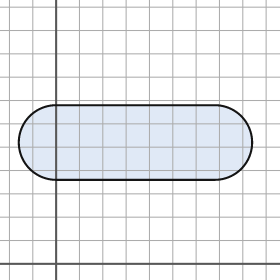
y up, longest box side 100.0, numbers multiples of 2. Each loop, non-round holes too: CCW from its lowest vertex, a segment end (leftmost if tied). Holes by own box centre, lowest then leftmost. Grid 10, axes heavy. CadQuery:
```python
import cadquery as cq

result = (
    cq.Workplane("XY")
    .moveTo(0.0, 36.0)
    .lineTo(68.0, 36.0)
    .threePointArc((84.0, 52.0), (68.0, 68.0))
    .lineTo(0.0, 68.0)
    .threePointArc((-16.0, 52.0), (0.0, 36.0))
    .close()
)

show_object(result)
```